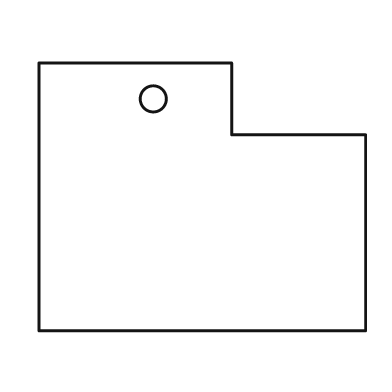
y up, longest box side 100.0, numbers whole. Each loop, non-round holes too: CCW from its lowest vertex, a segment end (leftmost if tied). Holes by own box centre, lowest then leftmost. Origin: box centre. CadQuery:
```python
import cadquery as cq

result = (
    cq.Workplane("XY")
    .moveTo(-50.0, -41.0)
    .lineTo(50.0, -41.0)
    .lineTo(50.0, 19.0)
    .lineTo(9.0, 19.0)
    .lineTo(9.0, 41.0)
    .lineTo(-50.0, 41.0)
    .close()
    .moveTo(-15.0, 30.0)
    .circle(4.0)
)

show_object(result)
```